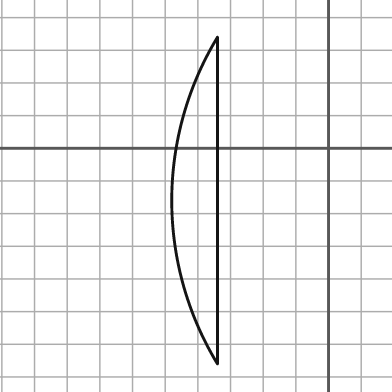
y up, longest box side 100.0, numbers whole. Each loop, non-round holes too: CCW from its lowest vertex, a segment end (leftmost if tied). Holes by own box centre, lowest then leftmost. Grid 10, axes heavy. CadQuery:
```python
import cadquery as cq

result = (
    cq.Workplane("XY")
    .moveTo(-34.0, -66.0)
    .lineTo(-34.0, 34.0)
    .threePointArc((-48.0, -16.0), (-34.0, -66.0))
    .close()
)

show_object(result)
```